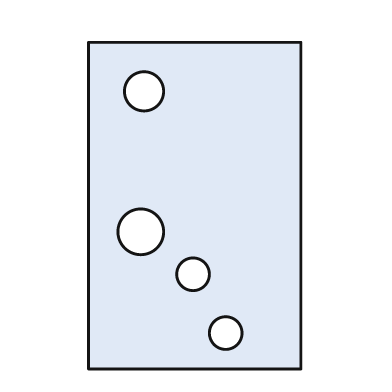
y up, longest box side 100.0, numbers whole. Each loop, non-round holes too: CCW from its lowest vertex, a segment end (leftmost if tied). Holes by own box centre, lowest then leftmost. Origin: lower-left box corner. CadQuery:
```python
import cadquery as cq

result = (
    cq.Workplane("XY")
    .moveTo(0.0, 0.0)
    .lineTo(65.0, 0.0)
    .lineTo(65.0, 100.0)
    .lineTo(0.0, 100.0)
    .close()
    .moveTo(42.0, 11.0)
    .circle(5.0)
    .moveTo(32.0, 29.0)
    .circle(5.0)
    .moveTo(16.0, 42.0)
    .circle(7.0)
    .moveTo(17.0, 85.0)
    .circle(6.0)
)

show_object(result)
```